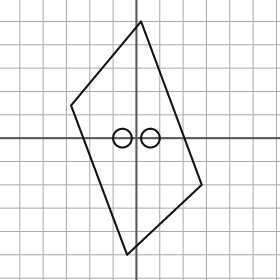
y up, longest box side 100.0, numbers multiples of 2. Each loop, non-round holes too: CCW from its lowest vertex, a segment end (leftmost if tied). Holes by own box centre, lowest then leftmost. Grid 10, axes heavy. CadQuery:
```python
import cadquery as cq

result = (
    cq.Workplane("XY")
    .moveTo(-4.0, -50.0)
    .lineTo(28.0, -20.0)
    .lineTo(2.0, 50.0)
    .lineTo(-28.0, 14.0)
    .close()
    .moveTo(-6.0, 0.0)
    .circle(4.0)
    .moveTo(6.0, 0.0)
    .circle(4.0)
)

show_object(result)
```